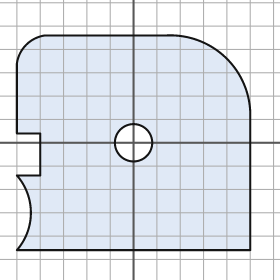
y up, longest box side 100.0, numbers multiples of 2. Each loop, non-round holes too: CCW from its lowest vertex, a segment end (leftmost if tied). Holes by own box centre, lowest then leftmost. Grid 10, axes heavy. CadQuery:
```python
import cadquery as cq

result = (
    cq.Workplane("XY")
    .moveTo(-50.0, -46.0)
    .lineTo(50.0, -46.0)
    .lineTo(50.0, 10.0)
    .threePointArc((40.0, 36.0), (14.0, 46.0))
    .lineTo(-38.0, 46.0)
    .threePointArc((-46.0, 42.0), (-50.0, 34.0))
    .lineTo(-50.0, 4.0)
    .lineTo(-40.0, 4.0)
    .lineTo(-40.0, -14.0)
    .lineTo(-50.0, -14.0)
    .threePointArc((-44.0, -30.0), (-50.0, -46.0))
    .close()
    .moveTo(0.0, 0.0)
    .circle(8.0)
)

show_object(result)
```